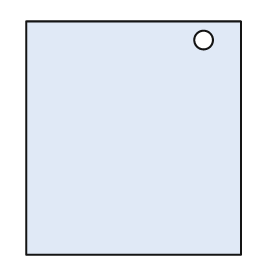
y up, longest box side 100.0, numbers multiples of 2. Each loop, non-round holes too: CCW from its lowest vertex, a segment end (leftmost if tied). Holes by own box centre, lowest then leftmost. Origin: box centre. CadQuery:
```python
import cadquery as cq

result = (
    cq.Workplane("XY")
    .moveTo(-46.0, -50.0)
    .lineTo(46.0, -50.0)
    .lineTo(46.0, 50.0)
    .lineTo(-46.0, 50.0)
    .close()
    .moveTo(30.0, 42.0)
    .circle(4.0)
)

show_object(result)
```